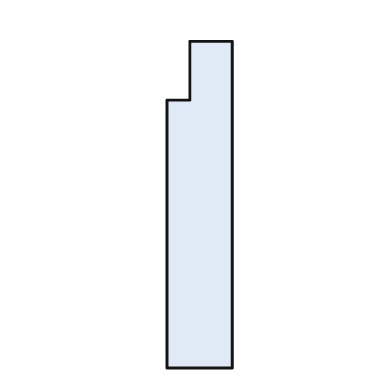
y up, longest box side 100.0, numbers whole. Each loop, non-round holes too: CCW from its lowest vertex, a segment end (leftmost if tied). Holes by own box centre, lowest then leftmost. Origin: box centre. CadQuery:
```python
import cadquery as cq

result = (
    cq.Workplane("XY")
    .moveTo(-10.0, -50.0)
    .lineTo(10.0, -50.0)
    .lineTo(10.0, 50.0)
    .lineTo(-3.0, 50.0)
    .lineTo(-3.0, 32.0)
    .lineTo(-10.0, 32.0)
    .close()
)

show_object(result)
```